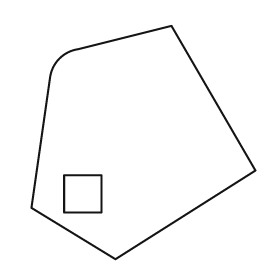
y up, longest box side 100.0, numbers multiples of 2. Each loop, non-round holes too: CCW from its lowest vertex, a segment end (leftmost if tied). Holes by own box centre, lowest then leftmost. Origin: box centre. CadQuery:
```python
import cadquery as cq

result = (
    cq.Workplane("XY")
    .moveTo(-12.0, -50.0)
    .lineTo(48.0, -12.0)
    .lineTo(12.0, 50.0)
    .lineTo(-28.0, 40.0)
    .threePointArc((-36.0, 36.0), (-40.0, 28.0))
    .lineTo(-48.0, -28.0)
    .close()
    .moveTo(-34.0, -30.0)
    .lineTo(-18.0, -30.0)
    .lineTo(-18.0, -14.0)
    .lineTo(-34.0, -14.0)
    .close()
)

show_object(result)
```